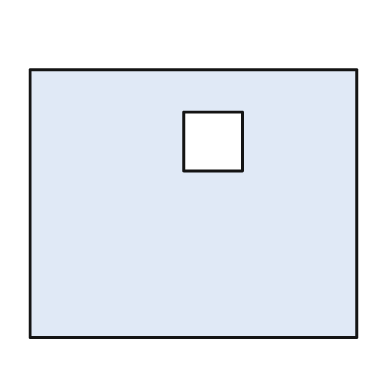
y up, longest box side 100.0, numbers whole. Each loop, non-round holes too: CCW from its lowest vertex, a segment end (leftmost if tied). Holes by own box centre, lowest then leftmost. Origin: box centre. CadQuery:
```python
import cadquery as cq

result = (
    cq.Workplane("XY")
    .moveTo(-50.0, -41.0)
    .lineTo(50.0, -41.0)
    .lineTo(50.0, 41.0)
    .lineTo(-50.0, 41.0)
    .close()
    .moveTo(-3.0, 10.0)
    .lineTo(15.0, 10.0)
    .lineTo(15.0, 28.0)
    .lineTo(-3.0, 28.0)
    .close()
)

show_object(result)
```